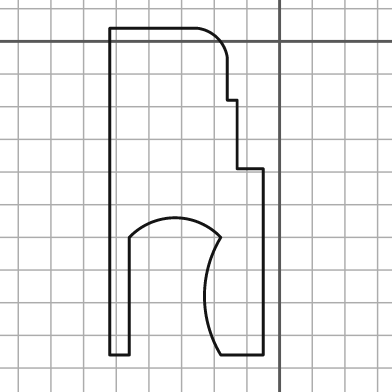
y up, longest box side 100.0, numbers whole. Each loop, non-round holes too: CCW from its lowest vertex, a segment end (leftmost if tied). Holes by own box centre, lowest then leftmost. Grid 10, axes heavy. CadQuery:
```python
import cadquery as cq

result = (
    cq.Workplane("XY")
    .moveTo(-52.0, -96.0)
    .lineTo(-46.0, -96.0)
    .lineTo(-46.0, -60.0)
    .threePointArc((-32.0, -54.0), (-18.0, -60.0))
    .threePointArc((-23.0, -78.0), (-18.0, -96.0))
    .lineTo(-5.0, -96.0)
    .lineTo(-5.0, -39.0)
    .lineTo(-13.0, -39.0)
    .lineTo(-13.0, -18.0)
    .lineTo(-16.0, -18.0)
    .lineTo(-16.0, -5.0)
    .threePointArc((-19.0, 1.0), (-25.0, 4.0))
    .lineTo(-52.0, 4.0)
    .close()
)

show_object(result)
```